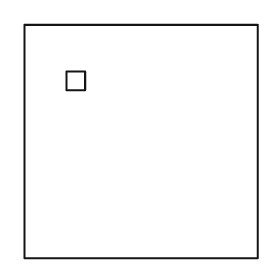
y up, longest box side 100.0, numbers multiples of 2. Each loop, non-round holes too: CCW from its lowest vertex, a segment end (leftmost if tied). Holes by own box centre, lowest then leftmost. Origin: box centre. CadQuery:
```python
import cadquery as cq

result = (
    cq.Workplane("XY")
    .moveTo(-50.0, -50.0)
    .lineTo(50.0, -50.0)
    .lineTo(50.0, 50.0)
    .lineTo(-50.0, 50.0)
    .close()
    .moveTo(-32.0, 22.0)
    .lineTo(-24.0, 22.0)
    .lineTo(-24.0, 30.0)
    .lineTo(-32.0, 30.0)
    .close()
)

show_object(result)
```